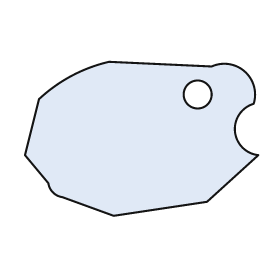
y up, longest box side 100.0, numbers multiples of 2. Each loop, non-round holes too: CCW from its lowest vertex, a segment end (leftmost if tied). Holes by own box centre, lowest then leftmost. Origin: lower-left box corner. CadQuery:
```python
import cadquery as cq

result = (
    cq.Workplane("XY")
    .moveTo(38.0, 0.0)
    .lineTo(78.0, 6.0)
    .lineTo(100.0, 26.0)
    .threePointArc((90.0, 36.0), (98.0, 48.0))
    .threePointArc((94.0, 62.0), (80.0, 64.0))
    .lineTo(36.0, 66.0)
    .threePointArc((20.0, 60.0), (6.0, 50.0))
    .lineTo(0.0, 26.0)
    .lineTo(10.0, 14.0)
    .threePointArc((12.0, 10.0), (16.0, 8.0))
    .close()
    .moveTo(74.0, 52.0)
    .circle(6.0)
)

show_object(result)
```